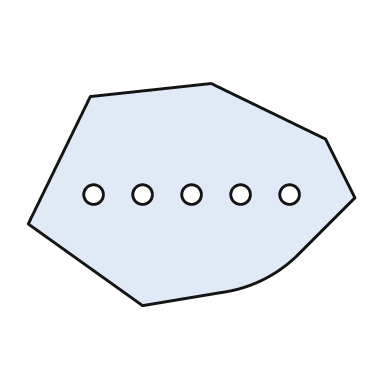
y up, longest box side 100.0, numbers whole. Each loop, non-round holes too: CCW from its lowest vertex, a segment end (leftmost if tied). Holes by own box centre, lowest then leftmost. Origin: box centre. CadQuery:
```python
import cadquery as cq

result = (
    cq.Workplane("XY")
    .moveTo(-15.0, -34.0)
    .lineTo(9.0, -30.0)
    .threePointArc((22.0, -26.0), (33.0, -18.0))
    .lineTo(50.0, -1.0)
    .lineTo(41.0, 17.0)
    .lineTo(6.0, 34.0)
    .lineTo(-31.0, 30.0)
    .lineTo(-50.0, -9.0)
    .close()
    .moveTo(-30.0, 0.0)
    .circle(3.0)
    .moveTo(-15.0, 0.0)
    .circle(3.0)
    .moveTo(0.0, 0.0)
    .circle(3.0)
    .moveTo(15.0, 0.0)
    .circle(3.0)
    .moveTo(30.0, 0.0)
    .circle(3.0)
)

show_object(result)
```